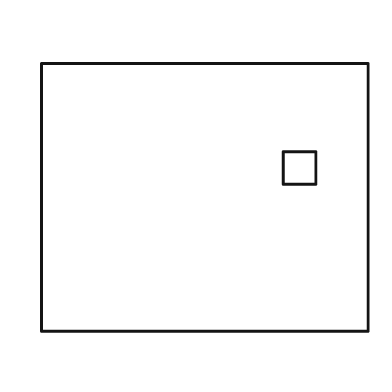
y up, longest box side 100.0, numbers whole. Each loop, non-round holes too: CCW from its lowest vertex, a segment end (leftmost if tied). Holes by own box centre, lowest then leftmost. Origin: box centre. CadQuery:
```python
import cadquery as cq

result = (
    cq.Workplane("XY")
    .moveTo(-50.0, -41.0)
    .lineTo(50.0, -41.0)
    .lineTo(50.0, 41.0)
    .lineTo(-50.0, 41.0)
    .close()
    .moveTo(24.0, 4.0)
    .lineTo(34.0, 4.0)
    .lineTo(34.0, 14.0)
    .lineTo(24.0, 14.0)
    .close()
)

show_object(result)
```